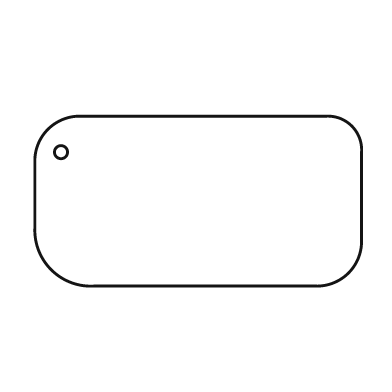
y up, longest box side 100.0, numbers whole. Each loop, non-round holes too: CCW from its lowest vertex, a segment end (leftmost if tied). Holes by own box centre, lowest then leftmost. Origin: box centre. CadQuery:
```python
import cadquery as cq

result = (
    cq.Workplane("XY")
    .moveTo(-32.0, -26.0)
    .lineTo(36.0, -26.0)
    .threePointArc((46.0, -22.0), (50.0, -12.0))
    .lineTo(50.0, 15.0)
    .threePointArc((47.0, 23.0), (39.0, 26.0))
    .lineTo(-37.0, 26.0)
    .threePointArc((-46.0, 22.0), (-50.0, 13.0))
    .lineTo(-50.0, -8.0)
    .threePointArc((-45.0, -21.0), (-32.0, -26.0))
    .close()
    .moveTo(-42.0, 15.0)
    .circle(2.0)
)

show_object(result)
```